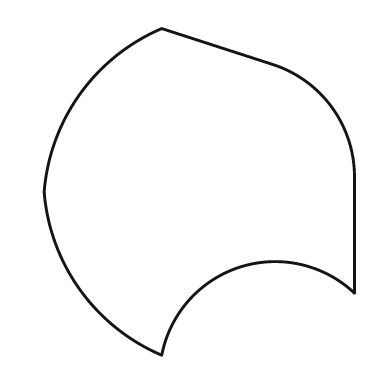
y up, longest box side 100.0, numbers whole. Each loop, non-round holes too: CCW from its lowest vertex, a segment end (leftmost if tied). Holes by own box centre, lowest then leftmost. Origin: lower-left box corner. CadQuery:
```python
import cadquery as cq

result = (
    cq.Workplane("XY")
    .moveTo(36.0, 0.0)
    .threePointArc((60.0, 27.0), (95.0, 19.0))
    .lineTo(95.0, 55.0)
    .threePointArc((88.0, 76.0), (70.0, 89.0))
    .lineTo(36.0, 100.0)
    .threePointArc((11.0, 80.0), (0.0, 50.0))
    .threePointArc((11.0, 20.0), (36.0, 0.0))
    .close()
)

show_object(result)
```